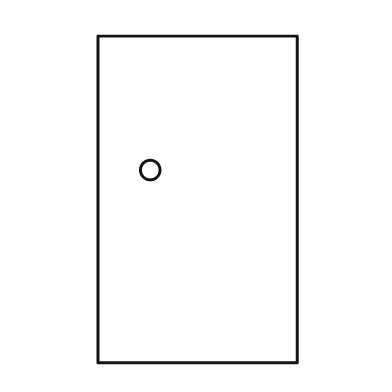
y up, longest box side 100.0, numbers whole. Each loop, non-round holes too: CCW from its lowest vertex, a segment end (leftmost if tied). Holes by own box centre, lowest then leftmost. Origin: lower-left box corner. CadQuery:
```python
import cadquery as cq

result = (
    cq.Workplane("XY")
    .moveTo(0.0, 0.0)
    .lineTo(61.0, 0.0)
    .lineTo(61.0, 100.0)
    .lineTo(0.0, 100.0)
    .close()
    .moveTo(16.0, 59.0)
    .circle(3.0)
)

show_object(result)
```